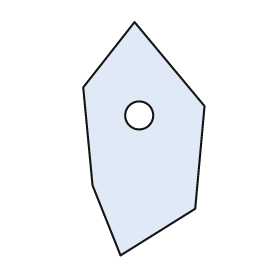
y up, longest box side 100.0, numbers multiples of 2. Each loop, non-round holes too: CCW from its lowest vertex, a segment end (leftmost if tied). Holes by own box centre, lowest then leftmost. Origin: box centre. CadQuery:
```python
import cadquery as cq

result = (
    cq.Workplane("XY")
    .moveTo(-10.0, -50.0)
    .lineTo(22.0, -30.0)
    .lineTo(26.0, 14.0)
    .lineTo(-4.0, 50.0)
    .lineTo(-26.0, 22.0)
    .lineTo(-22.0, -20.0)
    .close()
    .moveTo(-2.0, 10.0)
    .circle(6.0)
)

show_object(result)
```